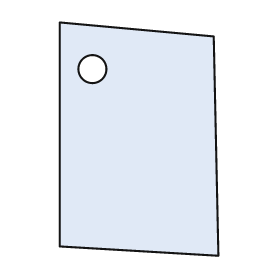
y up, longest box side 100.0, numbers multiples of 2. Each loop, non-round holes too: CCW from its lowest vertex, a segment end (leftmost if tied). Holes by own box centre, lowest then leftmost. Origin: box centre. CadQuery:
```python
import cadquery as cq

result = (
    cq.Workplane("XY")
    .moveTo(34.0, -50.0)
    .lineTo(32.0, 44.0)
    .lineTo(-34.0, 50.0)
    .lineTo(-34.0, -46.0)
    .close()
    .moveTo(-20.0, 30.0)
    .circle(6.0)
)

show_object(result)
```